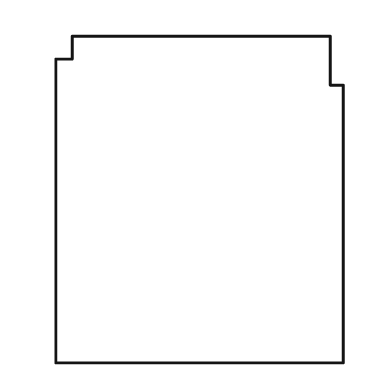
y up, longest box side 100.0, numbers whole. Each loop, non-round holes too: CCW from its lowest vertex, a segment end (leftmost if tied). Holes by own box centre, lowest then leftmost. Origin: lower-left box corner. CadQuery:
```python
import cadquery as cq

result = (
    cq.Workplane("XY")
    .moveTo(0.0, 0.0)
    .lineTo(88.0, 0.0)
    .lineTo(88.0, 85.0)
    .lineTo(84.0, 85.0)
    .lineTo(84.0, 100.0)
    .lineTo(5.0, 100.0)
    .lineTo(5.0, 93.0)
    .lineTo(0.0, 93.0)
    .close()
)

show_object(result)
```